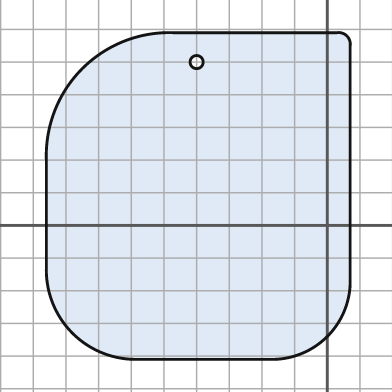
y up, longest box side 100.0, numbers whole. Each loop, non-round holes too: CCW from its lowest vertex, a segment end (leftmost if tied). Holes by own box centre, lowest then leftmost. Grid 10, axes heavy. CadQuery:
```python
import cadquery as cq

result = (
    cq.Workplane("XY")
    .moveTo(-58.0, -41.0)
    .lineTo(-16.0, -41.0)
    .threePointArc((0.0, -34.0), (7.0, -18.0))
    .lineTo(7.0, 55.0)
    .threePointArc((6.0, 58.0), (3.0, 59.0))
    .lineTo(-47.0, 59.0)
    .threePointArc((-75.0, 48.0), (-86.0, 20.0))
    .lineTo(-86.0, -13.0)
    .threePointArc((-78.0, -33.0), (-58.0, -41.0))
    .close()
    .moveTo(-40.0, 50.0)
    .circle(2.0)
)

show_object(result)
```